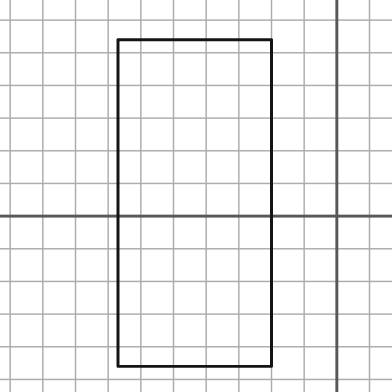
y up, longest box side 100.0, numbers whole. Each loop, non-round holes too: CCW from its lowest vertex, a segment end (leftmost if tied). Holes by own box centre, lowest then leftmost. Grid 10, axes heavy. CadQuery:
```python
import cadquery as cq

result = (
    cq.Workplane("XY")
    .moveTo(-67.0, -46.0)
    .lineTo(-20.0, -46.0)
    .lineTo(-20.0, 54.0)
    .lineTo(-67.0, 54.0)
    .close()
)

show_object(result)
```